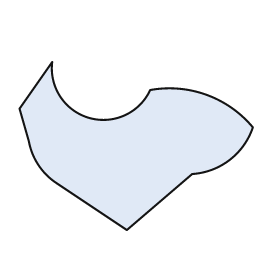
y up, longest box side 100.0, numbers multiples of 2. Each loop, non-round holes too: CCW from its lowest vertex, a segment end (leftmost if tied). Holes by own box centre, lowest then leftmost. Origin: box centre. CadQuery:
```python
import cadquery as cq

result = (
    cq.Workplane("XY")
    .moveTo(-4.0, -36.0)
    .lineTo(24.0, -12.0)
    .threePointArc((40.0, -6.0), (50.0, 8.0))
    .threePointArc((30.0, 22.0), (6.0, 24.0))
    .threePointArc((-20.0, 12.0), (-36.0, 36.0))
    .lineTo(-50.0, 16.0)
    .lineTo(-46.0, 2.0)
    .threePointArc((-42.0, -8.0), (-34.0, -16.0))
    .close()
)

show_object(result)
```